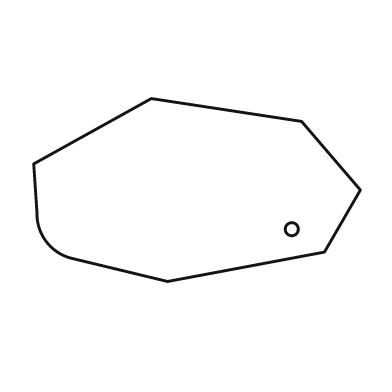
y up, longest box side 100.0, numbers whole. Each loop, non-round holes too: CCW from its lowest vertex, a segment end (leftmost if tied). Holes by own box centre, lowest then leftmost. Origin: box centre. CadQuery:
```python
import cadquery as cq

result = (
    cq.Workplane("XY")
    .moveTo(-9.0, -28.0)
    .lineTo(39.0, -19.0)
    .lineTo(50.0, 0.0)
    .lineTo(32.0, 21.0)
    .lineTo(-14.0, 28.0)
    .lineTo(-50.0, 8.0)
    .lineTo(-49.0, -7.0)
    .threePointArc((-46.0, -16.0), (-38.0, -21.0))
    .close()
    .moveTo(29.0, -12.0)
    .circle(2.0)
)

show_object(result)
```